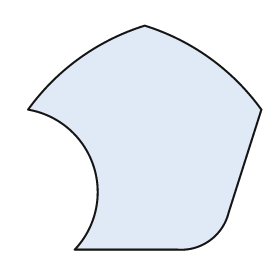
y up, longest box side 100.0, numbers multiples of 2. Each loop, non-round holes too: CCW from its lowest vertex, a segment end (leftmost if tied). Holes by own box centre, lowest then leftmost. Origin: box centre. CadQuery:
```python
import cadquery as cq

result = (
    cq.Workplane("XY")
    .moveTo(-30.0, -48.0)
    .lineTo(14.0, -48.0)
    .threePointArc((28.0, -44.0), (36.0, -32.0))
    .lineTo(50.0, 12.0)
    .threePointArc((28.0, 34.0), (0.0, 48.0))
    .threePointArc((-28.0, 34.0), (-50.0, 12.0))
    .threePointArc((-22.0, -12.0), (-30.0, -48.0))
    .close()
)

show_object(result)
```